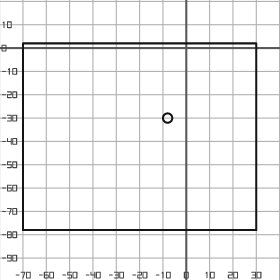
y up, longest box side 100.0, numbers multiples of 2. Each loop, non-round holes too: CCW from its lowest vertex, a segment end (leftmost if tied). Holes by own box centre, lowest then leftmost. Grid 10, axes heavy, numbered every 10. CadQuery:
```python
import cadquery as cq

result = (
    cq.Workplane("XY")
    .moveTo(-70.0, -78.0)
    .lineTo(30.0, -78.0)
    .lineTo(30.0, 2.0)
    .lineTo(-70.0, 2.0)
    .close()
    .moveTo(-8.0, -30.0)
    .circle(2.0)
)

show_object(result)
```